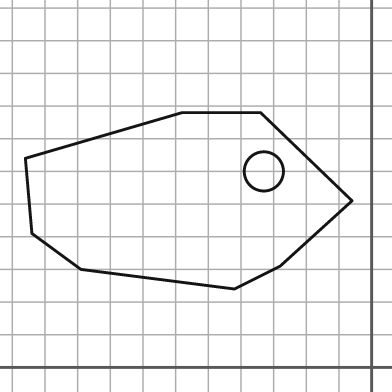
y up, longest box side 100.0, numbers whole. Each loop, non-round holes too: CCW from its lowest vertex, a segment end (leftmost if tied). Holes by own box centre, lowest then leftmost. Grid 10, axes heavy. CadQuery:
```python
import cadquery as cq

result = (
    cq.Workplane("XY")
    .moveTo(-42.0, 24.0)
    .lineTo(-28.0, 31.0)
    .lineTo(-6.0, 51.0)
    .lineTo(-34.0, 78.0)
    .lineTo(-58.0, 78.0)
    .lineTo(-106.0, 64.0)
    .lineTo(-104.0, 41.0)
    .lineTo(-89.0, 30.0)
    .close()
    .moveTo(-33.0, 60.0)
    .circle(6.0)
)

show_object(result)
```